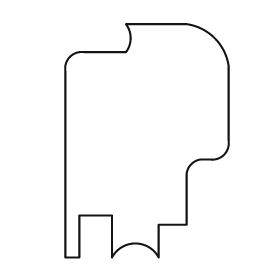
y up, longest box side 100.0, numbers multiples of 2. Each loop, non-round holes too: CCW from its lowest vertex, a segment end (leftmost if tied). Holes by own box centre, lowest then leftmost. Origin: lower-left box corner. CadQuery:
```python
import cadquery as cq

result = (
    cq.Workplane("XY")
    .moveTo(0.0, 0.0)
    .lineTo(6.0, 0.0)
    .lineTo(6.0, 18.0)
    .lineTo(20.0, 18.0)
    .lineTo(20.0, 0.0)
    .threePointArc((30.0, 6.0), (40.0, 0.0))
    .lineTo(40.0, 14.0)
    .lineTo(52.0, 14.0)
    .lineTo(52.0, 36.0)
    .threePointArc((54.0, 40.0), (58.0, 42.0))
    .lineTo(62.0, 42.0)
    .threePointArc((68.0, 44.0), (70.0, 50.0))
    .lineTo(70.0, 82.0)
    .threePointArc((64.0, 94.0), (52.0, 100.0))
    .lineTo(26.0, 100.0)
    .threePointArc((28.0, 94.0), (26.0, 88.0))
    .lineTo(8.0, 88.0)
    .threePointArc((2.0, 86.0), (0.0, 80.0))
    .close()
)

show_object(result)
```